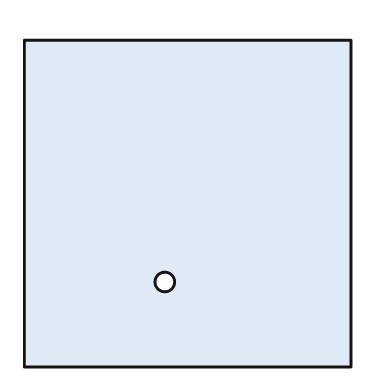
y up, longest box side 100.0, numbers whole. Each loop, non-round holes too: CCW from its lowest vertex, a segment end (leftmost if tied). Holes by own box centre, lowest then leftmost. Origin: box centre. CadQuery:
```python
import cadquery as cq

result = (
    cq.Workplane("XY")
    .moveTo(-50.0, -50.0)
    .lineTo(50.0, -50.0)
    .lineTo(50.0, 50.0)
    .lineTo(-50.0, 50.0)
    .close()
    .moveTo(-7.0, -24.0)
    .circle(3.0)
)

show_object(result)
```